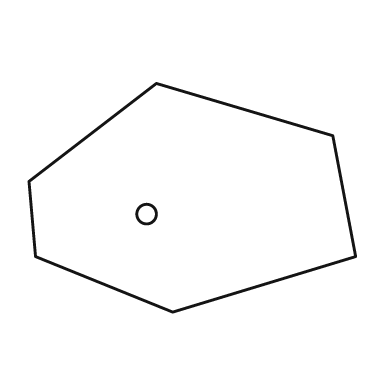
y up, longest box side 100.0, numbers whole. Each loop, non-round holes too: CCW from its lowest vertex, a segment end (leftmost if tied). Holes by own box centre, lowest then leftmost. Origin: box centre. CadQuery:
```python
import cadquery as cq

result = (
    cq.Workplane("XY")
    .moveTo(-6.0, -35.0)
    .lineTo(50.0, -18.0)
    .lineTo(43.0, 19.0)
    .lineTo(-11.0, 35.0)
    .lineTo(-50.0, 5.0)
    .lineTo(-48.0, -18.0)
    .close()
    .moveTo(-14.0, -5.0)
    .circle(3.0)
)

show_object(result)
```